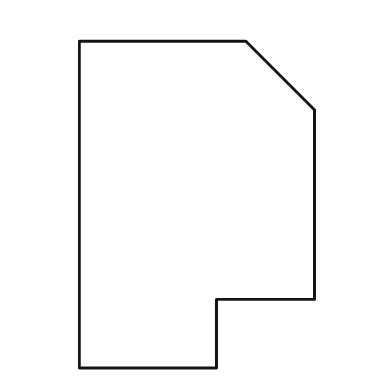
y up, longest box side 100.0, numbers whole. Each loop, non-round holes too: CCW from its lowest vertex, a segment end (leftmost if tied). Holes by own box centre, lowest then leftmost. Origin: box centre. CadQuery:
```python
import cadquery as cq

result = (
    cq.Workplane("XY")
    .moveTo(-36.0, -50.0)
    .lineTo(6.0, -50.0)
    .lineTo(6.0, -29.0)
    .lineTo(36.0, -29.0)
    .lineTo(36.0, 29.0)
    .lineTo(15.0, 50.0)
    .lineTo(-36.0, 50.0)
    .close()
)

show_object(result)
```